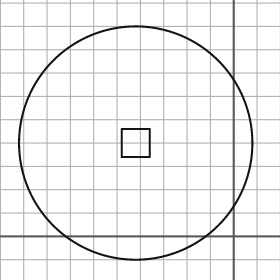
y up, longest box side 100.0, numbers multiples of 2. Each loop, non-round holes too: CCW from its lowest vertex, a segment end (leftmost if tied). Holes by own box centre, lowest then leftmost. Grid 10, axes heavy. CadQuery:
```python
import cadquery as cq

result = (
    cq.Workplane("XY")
    .moveTo(-42.0, 40.0)
    .circle(50.0)
    .moveTo(-48.0, 34.0)
    .lineTo(-36.0, 34.0)
    .lineTo(-36.0, 46.0)
    .lineTo(-48.0, 46.0)
    .close()
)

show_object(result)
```